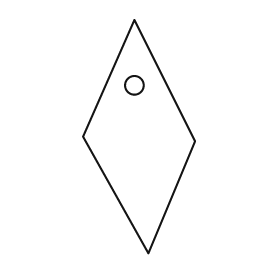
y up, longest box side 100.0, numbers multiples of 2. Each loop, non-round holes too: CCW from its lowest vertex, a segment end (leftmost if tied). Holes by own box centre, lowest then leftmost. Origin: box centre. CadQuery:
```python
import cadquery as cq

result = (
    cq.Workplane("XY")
    .moveTo(4.0, -50.0)
    .lineTo(24.0, -2.0)
    .lineTo(-2.0, 50.0)
    .lineTo(-24.0, 0.0)
    .close()
    .moveTo(-2.0, 22.0)
    .circle(4.0)
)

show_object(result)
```